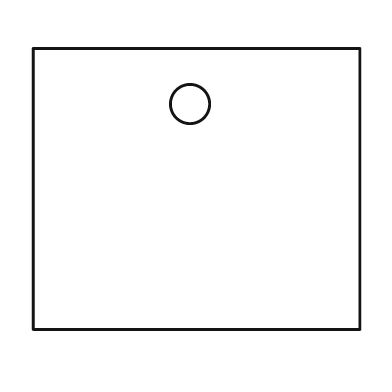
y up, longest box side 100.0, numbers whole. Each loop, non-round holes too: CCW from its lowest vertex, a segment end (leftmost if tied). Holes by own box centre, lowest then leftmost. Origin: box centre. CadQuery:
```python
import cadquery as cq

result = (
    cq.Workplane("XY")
    .moveTo(-50.0, -43.0)
    .lineTo(50.0, -43.0)
    .lineTo(50.0, 43.0)
    .lineTo(-50.0, 43.0)
    .close()
    .moveTo(-2.0, 26.0)
    .circle(6.0)
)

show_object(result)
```